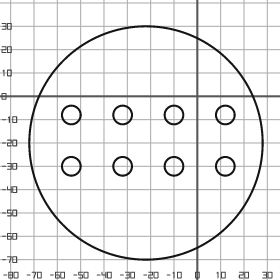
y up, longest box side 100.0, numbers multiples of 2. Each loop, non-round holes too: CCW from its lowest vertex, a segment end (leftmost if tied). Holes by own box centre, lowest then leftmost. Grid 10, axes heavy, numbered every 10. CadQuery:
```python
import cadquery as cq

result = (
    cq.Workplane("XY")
    .moveTo(-22.0, -20.0)
    .circle(50.0)
    .moveTo(-54.0, -30.0)
    .circle(4.0)
    .moveTo(-32.0, -30.0)
    .circle(4.0)
    .moveTo(-10.0, -30.0)
    .circle(4.0)
    .moveTo(12.0, -30.0)
    .circle(4.0)
    .moveTo(-54.0, -8.0)
    .circle(4.0)
    .moveTo(-32.0, -8.0)
    .circle(4.0)
    .moveTo(-10.0, -8.0)
    .circle(4.0)
    .moveTo(12.0, -8.0)
    .circle(4.0)
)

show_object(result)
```